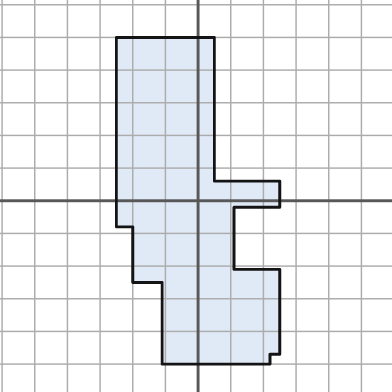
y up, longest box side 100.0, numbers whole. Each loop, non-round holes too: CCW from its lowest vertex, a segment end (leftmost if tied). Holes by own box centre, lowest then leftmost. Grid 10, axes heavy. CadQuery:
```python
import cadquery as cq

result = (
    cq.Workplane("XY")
    .moveTo(-11.0, -50.0)
    .lineTo(22.0, -50.0)
    .lineTo(22.0, -47.0)
    .lineTo(25.0, -47.0)
    .lineTo(25.0, -21.0)
    .lineTo(11.0, -21.0)
    .lineTo(11.0, -2.0)
    .lineTo(25.0, -2.0)
    .lineTo(25.0, 6.0)
    .lineTo(5.0, 6.0)
    .lineTo(5.0, 50.0)
    .lineTo(-25.0, 50.0)
    .lineTo(-25.0, -8.0)
    .lineTo(-20.0, -8.0)
    .lineTo(-20.0, -25.0)
    .lineTo(-11.0, -25.0)
    .close()
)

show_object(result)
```